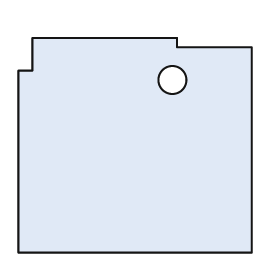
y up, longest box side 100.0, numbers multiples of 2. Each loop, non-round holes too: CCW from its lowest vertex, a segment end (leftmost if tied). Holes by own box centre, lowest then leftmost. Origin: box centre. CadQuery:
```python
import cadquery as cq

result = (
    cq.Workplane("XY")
    .moveTo(-50.0, -46.0)
    .lineTo(50.0, -46.0)
    .lineTo(50.0, 42.0)
    .lineTo(18.0, 42.0)
    .lineTo(18.0, 46.0)
    .lineTo(-44.0, 46.0)
    .lineTo(-44.0, 32.0)
    .lineTo(-50.0, 32.0)
    .close()
    .moveTo(16.0, 28.0)
    .circle(6.0)
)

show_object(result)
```